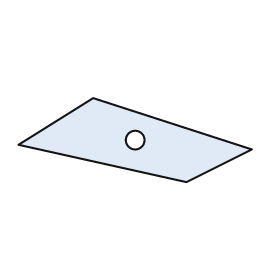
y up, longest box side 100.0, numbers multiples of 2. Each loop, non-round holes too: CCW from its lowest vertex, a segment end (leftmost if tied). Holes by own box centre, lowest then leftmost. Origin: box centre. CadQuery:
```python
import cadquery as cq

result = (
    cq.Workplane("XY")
    .moveTo(22.0, -18.0)
    .lineTo(50.0, -4.0)
    .lineTo(-18.0, 18.0)
    .lineTo(-50.0, -2.0)
    .close()
    .moveTo(0.0, 0.0)
    .circle(4.0)
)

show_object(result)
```